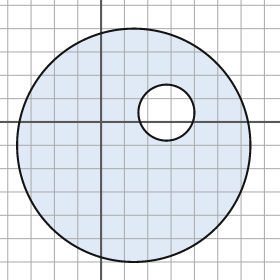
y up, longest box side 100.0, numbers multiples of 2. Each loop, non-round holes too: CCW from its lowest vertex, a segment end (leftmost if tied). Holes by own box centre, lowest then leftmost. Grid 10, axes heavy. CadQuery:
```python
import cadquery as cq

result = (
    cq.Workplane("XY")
    .moveTo(14.0, -10.0)
    .circle(50.0)
    .moveTo(28.0, 4.0)
    .circle(12.0)
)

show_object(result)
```